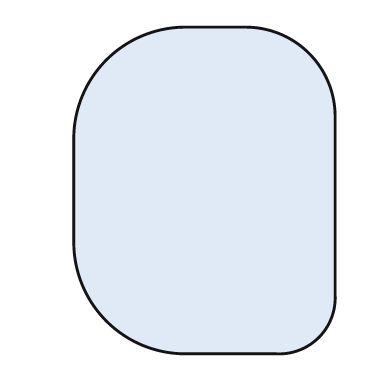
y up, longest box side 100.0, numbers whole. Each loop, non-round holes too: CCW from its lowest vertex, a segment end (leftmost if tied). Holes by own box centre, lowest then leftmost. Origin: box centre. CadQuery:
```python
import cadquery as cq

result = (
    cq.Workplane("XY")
    .moveTo(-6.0, -50.0)
    .lineTo(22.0, -50.0)
    .threePointArc((35.0, -45.0), (40.0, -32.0))
    .lineTo(40.0, 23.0)
    .threePointArc((32.0, 42.0), (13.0, 50.0))
    .lineTo(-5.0, 50.0)
    .threePointArc((-30.0, 40.0), (-40.0, 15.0))
    .lineTo(-40.0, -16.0)
    .threePointArc((-30.0, -40.0), (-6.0, -50.0))
    .close()
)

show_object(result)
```